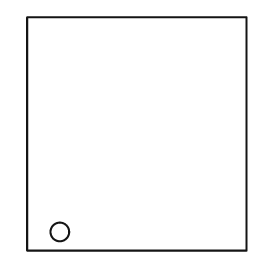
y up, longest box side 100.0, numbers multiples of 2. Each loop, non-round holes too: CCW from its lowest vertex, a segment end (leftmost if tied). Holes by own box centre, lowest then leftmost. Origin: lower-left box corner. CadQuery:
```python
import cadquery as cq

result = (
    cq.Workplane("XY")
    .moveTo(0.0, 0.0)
    .lineTo(94.0, 0.0)
    .lineTo(94.0, 100.0)
    .lineTo(0.0, 100.0)
    .close()
    .moveTo(14.0, 8.0)
    .circle(4.0)
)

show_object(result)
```